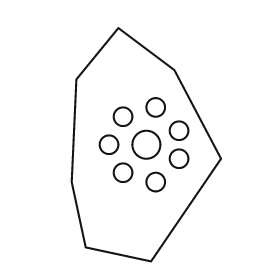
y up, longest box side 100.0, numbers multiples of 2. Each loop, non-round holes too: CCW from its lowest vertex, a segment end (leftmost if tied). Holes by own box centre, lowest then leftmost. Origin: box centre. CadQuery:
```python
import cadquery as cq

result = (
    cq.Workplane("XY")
    .moveTo(2.0, -50.0)
    .lineTo(32.0, -6.0)
    .lineTo(12.0, 32.0)
    .lineTo(-12.0, 50.0)
    .lineTo(-30.0, 28.0)
    .lineTo(-32.0, -16.0)
    .lineTo(-26.0, -44.0)
    .close()
    .moveTo(4.0, -16.0)
    .circle(4.0)
    .moveTo(-10.0, -12.0)
    .circle(4.0)
    .moveTo(14.0, -6.0)
    .circle(4.0)
    .moveTo(-16.0, 0.0)
    .circle(4.0)
    .moveTo(0.0, 0.0)
    .circle(6.0)
    .moveTo(14.0, 6.0)
    .circle(4.0)
    .moveTo(-10.0, 12.0)
    .circle(4.0)
    .moveTo(4.0, 16.0)
    .circle(4.0)
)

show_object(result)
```